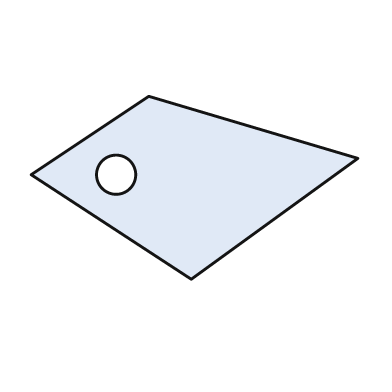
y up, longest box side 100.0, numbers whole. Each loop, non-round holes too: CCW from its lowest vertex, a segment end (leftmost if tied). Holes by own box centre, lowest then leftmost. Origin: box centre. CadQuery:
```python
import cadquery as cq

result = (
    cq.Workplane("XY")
    .moveTo(-1.0, -28.0)
    .lineTo(50.0, 9.0)
    .lineTo(-14.0, 28.0)
    .lineTo(-50.0, 4.0)
    .close()
    .moveTo(-24.0, 4.0)
    .circle(6.0)
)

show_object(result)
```